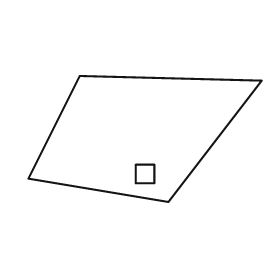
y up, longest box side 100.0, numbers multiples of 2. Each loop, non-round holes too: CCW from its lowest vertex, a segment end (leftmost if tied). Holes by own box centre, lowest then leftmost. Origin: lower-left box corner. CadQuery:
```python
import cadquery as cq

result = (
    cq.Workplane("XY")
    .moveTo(60.0, 0.0)
    .lineTo(100.0, 52.0)
    .lineTo(22.0, 54.0)
    .lineTo(0.0, 10.0)
    .close()
    .moveTo(46.0, 8.0)
    .lineTo(54.0, 8.0)
    .lineTo(54.0, 16.0)
    .lineTo(46.0, 16.0)
    .close()
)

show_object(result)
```